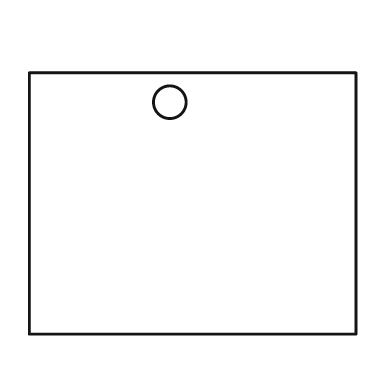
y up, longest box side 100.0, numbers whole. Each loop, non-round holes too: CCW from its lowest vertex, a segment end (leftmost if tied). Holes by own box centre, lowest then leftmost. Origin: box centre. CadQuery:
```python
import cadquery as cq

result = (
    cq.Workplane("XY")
    .moveTo(-50.0, -40.0)
    .lineTo(50.0, -40.0)
    .lineTo(50.0, 40.0)
    .lineTo(-50.0, 40.0)
    .close()
    .moveTo(-7.0, 31.0)
    .circle(5.0)
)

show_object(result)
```